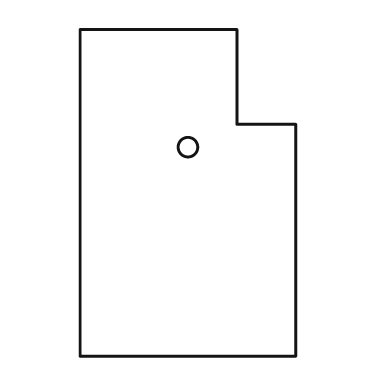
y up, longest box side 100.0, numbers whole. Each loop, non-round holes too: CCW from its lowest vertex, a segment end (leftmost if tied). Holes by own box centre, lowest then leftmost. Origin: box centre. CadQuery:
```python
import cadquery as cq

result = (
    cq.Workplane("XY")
    .moveTo(-33.0, -50.0)
    .lineTo(33.0, -50.0)
    .lineTo(33.0, 21.0)
    .lineTo(15.0, 21.0)
    .lineTo(15.0, 50.0)
    .lineTo(-33.0, 50.0)
    .close()
    .moveTo(0.0, 14.0)
    .circle(3.0)
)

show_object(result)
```